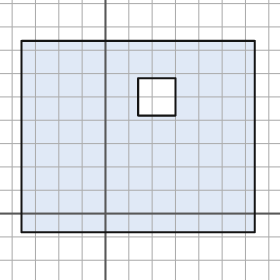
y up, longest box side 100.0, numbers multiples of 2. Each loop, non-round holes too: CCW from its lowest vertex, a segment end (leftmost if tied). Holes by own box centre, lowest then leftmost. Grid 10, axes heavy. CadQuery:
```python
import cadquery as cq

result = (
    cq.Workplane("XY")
    .moveTo(-36.0, -8.0)
    .lineTo(64.0, -8.0)
    .lineTo(64.0, 74.0)
    .lineTo(-36.0, 74.0)
    .close()
    .moveTo(14.0, 42.0)
    .lineTo(30.0, 42.0)
    .lineTo(30.0, 58.0)
    .lineTo(14.0, 58.0)
    .close()
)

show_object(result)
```